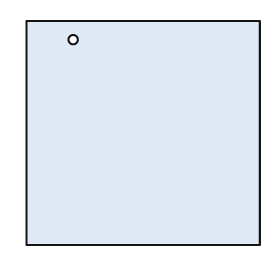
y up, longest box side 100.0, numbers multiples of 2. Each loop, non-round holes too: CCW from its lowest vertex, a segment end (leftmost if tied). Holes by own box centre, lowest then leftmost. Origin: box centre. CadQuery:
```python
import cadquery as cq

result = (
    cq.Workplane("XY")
    .moveTo(-50.0, -48.0)
    .lineTo(50.0, -48.0)
    .lineTo(50.0, 48.0)
    .lineTo(-50.0, 48.0)
    .close()
    .moveTo(-30.0, 40.0)
    .circle(2.0)
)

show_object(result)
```